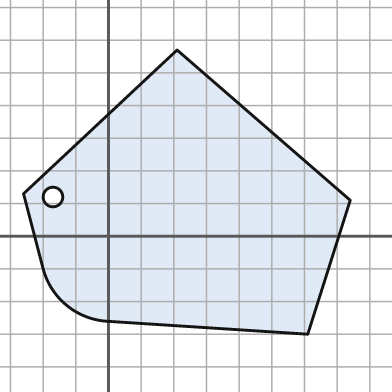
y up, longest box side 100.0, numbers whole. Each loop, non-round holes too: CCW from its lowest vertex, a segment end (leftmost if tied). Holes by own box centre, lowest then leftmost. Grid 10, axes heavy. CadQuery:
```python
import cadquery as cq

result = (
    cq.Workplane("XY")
    .moveTo(61.0, -30.0)
    .lineTo(74.0, 11.0)
    .lineTo(21.0, 57.0)
    .lineTo(-26.0, 13.0)
    .lineTo(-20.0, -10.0)
    .threePointArc((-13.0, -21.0), (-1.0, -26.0))
    .close()
    .moveTo(-17.0, 12.0)
    .circle(3.0)
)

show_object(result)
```